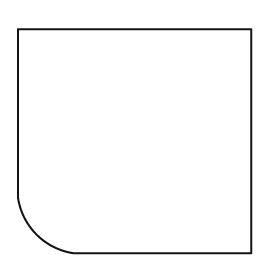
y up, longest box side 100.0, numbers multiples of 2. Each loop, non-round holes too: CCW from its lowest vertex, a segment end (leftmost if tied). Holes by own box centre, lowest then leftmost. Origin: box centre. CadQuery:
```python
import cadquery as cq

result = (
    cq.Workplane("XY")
    .moveTo(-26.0, -48.0)
    .lineTo(50.0, -48.0)
    .lineTo(50.0, 48.0)
    .lineTo(-50.0, 48.0)
    .lineTo(-50.0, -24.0)
    .threePointArc((-42.0, -40.0), (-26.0, -48.0))
    .close()
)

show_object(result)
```